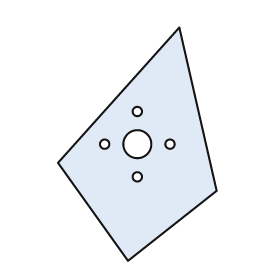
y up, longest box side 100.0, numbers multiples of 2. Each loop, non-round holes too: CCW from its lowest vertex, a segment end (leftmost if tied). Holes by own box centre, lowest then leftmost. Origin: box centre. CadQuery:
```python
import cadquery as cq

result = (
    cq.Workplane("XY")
    .moveTo(-4.0, -50.0)
    .lineTo(34.0, -20.0)
    .lineTo(18.0, 50.0)
    .lineTo(-34.0, -8.0)
    .close()
    .moveTo(0.0, -14.0)
    .circle(2.0)
    .moveTo(-14.0, 0.0)
    .circle(2.0)
    .moveTo(0.0, 0.0)
    .circle(6.0)
    .moveTo(14.0, 0.0)
    .circle(2.0)
    .moveTo(0.0, 14.0)
    .circle(2.0)
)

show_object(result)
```